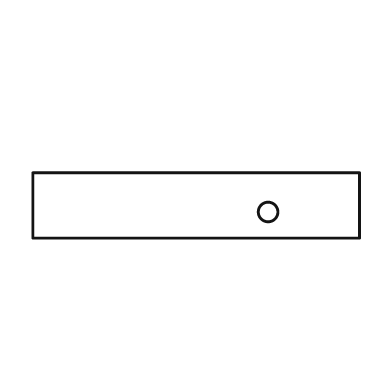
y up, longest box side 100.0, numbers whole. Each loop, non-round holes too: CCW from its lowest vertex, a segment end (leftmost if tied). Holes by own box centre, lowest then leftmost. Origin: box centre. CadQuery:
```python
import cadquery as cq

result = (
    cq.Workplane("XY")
    .moveTo(-50.0, -10.0)
    .lineTo(50.0, -10.0)
    .lineTo(50.0, 10.0)
    .lineTo(-50.0, 10.0)
    .close()
    .moveTo(22.0, -2.0)
    .circle(3.0)
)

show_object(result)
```